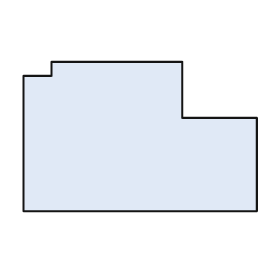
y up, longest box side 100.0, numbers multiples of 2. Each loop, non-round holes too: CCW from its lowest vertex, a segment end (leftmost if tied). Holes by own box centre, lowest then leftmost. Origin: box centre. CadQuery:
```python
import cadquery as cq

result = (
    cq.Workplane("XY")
    .moveTo(-50.0, -32.0)
    .lineTo(50.0, -32.0)
    .lineTo(50.0, 8.0)
    .lineTo(18.0, 8.0)
    .lineTo(18.0, 32.0)
    .lineTo(-38.0, 32.0)
    .lineTo(-38.0, 26.0)
    .lineTo(-50.0, 26.0)
    .close()
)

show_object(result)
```